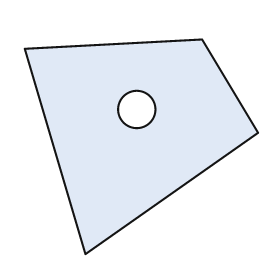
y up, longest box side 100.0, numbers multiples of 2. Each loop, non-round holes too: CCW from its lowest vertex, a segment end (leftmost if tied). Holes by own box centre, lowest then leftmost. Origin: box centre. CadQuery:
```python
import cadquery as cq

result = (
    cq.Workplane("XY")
    .moveTo(-24.0, -46.0)
    .lineTo(50.0, 6.0)
    .lineTo(26.0, 46.0)
    .lineTo(-50.0, 42.0)
    .close()
    .moveTo(-2.0, 16.0)
    .circle(8.0)
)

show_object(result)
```